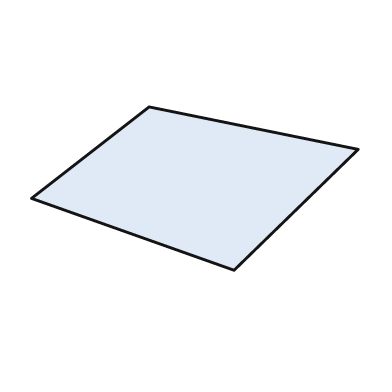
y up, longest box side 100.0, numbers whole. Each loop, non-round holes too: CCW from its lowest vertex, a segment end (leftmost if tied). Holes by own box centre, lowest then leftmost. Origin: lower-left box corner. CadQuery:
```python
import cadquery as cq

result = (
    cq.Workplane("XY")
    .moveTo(62.0, 0.0)
    .lineTo(100.0, 37.0)
    .lineTo(36.0, 50.0)
    .lineTo(0.0, 22.0)
    .close()
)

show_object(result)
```